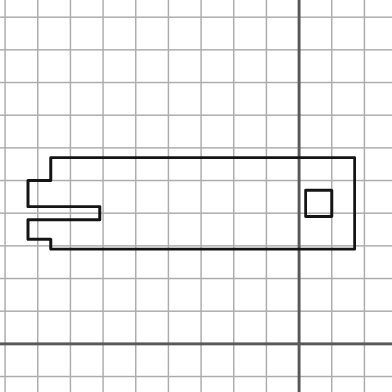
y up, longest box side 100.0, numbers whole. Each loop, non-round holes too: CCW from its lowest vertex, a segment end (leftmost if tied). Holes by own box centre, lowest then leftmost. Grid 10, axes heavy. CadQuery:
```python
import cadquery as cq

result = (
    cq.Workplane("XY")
    .moveTo(-76.0, 29.0)
    .lineTo(17.0, 29.0)
    .lineTo(17.0, 57.0)
    .lineTo(-76.0, 57.0)
    .lineTo(-76.0, 50.0)
    .lineTo(-83.0, 50.0)
    .lineTo(-83.0, 42.0)
    .lineTo(-61.0, 42.0)
    .lineTo(-61.0, 38.0)
    .lineTo(-83.0, 38.0)
    .lineTo(-83.0, 32.0)
    .lineTo(-76.0, 32.0)
    .close()
    .moveTo(2.0, 39.0)
    .lineTo(10.0, 39.0)
    .lineTo(10.0, 47.0)
    .lineTo(2.0, 47.0)
    .close()
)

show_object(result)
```